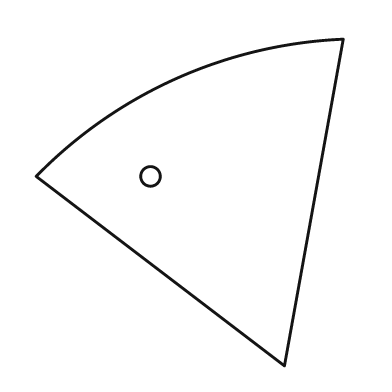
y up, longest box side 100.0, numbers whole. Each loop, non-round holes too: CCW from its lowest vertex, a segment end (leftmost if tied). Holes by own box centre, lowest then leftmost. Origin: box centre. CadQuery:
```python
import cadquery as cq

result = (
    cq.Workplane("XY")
    .moveTo(29.0, -50.0)
    .lineTo(47.0, 50.0)
    .threePointArc((-4.0, 38.0), (-47.0, 8.0))
    .close()
    .moveTo(-12.0, 8.0)
    .circle(3.0)
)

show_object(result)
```